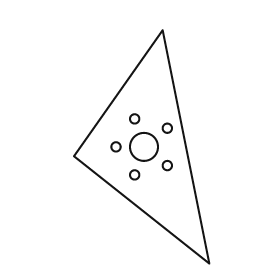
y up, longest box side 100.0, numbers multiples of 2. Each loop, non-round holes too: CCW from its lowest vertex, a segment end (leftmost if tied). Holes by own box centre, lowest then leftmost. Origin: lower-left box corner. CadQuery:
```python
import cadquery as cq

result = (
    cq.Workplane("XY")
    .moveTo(58.0, 0.0)
    .lineTo(38.0, 100.0)
    .lineTo(0.0, 46.0)
    .close()
    .moveTo(26.0, 38.0)
    .circle(2.0)
    .moveTo(40.0, 42.0)
    .circle(2.0)
    .moveTo(18.0, 50.0)
    .circle(2.0)
    .moveTo(30.0, 50.0)
    .circle(6.0)
    .moveTo(40.0, 58.0)
    .circle(2.0)
    .moveTo(26.0, 62.0)
    .circle(2.0)
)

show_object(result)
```